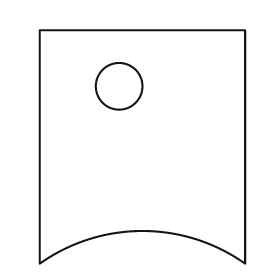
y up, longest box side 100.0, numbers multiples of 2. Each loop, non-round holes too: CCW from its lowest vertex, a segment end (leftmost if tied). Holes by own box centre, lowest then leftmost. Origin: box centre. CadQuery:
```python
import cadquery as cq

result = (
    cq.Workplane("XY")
    .moveTo(-44.0, -50.0)
    .threePointArc((0.0, -36.0), (44.0, -50.0))
    .lineTo(44.0, 50.0)
    .lineTo(-44.0, 50.0)
    .close()
    .moveTo(-10.0, 26.0)
    .circle(10.0)
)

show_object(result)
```